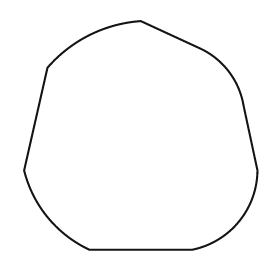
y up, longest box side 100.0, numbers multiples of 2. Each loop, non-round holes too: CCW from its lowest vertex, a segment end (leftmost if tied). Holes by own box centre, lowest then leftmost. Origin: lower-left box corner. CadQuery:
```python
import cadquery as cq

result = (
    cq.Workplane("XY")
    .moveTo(28.0, 0.0)
    .lineTo(72.0, 0.0)
    .threePointArc((92.0, 12.0), (100.0, 34.0))
    .lineTo(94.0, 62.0)
    .threePointArc((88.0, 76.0), (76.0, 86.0))
    .lineTo(50.0, 98.0)
    .threePointArc((28.0, 92.0), (10.0, 78.0))
    .lineTo(0.0, 34.0)
    .threePointArc((10.0, 14.0), (28.0, 0.0))
    .close()
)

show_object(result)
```